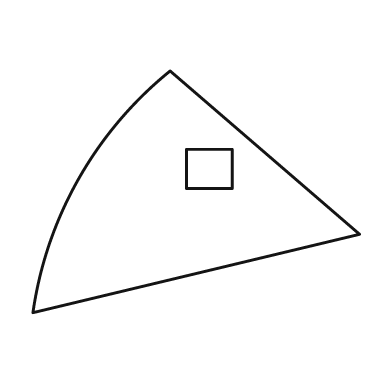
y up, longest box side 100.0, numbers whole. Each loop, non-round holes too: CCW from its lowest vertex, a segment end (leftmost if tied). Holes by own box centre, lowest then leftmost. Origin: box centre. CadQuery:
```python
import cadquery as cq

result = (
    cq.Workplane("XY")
    .moveTo(-50.0, -37.0)
    .lineTo(50.0, -13.0)
    .lineTo(-8.0, 37.0)
    .threePointArc((-36.0, 4.0), (-50.0, -37.0))
    .close()
    .moveTo(-3.0, 1.0)
    .lineTo(11.0, 1.0)
    .lineTo(11.0, 13.0)
    .lineTo(-3.0, 13.0)
    .close()
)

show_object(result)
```